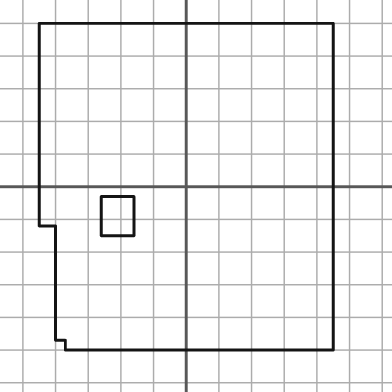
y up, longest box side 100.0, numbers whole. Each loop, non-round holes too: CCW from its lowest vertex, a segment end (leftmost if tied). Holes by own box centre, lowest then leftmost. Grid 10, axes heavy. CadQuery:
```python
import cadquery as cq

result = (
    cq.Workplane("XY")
    .moveTo(-37.0, -50.0)
    .lineTo(45.0, -50.0)
    .lineTo(45.0, 50.0)
    .lineTo(-45.0, 50.0)
    .lineTo(-45.0, -12.0)
    .lineTo(-40.0, -12.0)
    .lineTo(-40.0, -47.0)
    .lineTo(-37.0, -47.0)
    .close()
    .moveTo(-26.0, -15.0)
    .lineTo(-16.0, -15.0)
    .lineTo(-16.0, -3.0)
    .lineTo(-26.0, -3.0)
    .close()
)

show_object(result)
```